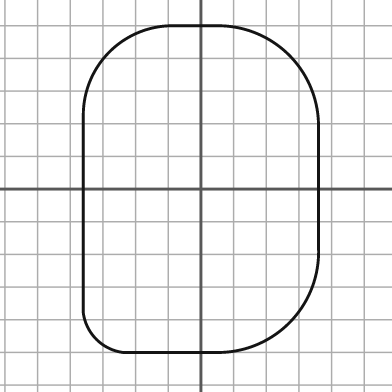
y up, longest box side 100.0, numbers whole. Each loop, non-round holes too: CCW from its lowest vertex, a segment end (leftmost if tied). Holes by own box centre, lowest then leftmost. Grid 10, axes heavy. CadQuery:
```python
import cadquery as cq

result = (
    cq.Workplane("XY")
    .moveTo(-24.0, -50.0)
    .lineTo(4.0, -50.0)
    .threePointArc((27.0, -41.0), (36.0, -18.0))
    .lineTo(36.0, 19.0)
    .threePointArc((27.0, 41.0), (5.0, 50.0))
    .lineTo(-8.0, 50.0)
    .threePointArc((-28.0, 42.0), (-36.0, 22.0))
    .lineTo(-36.0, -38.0)
    .threePointArc((-32.0, -46.0), (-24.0, -50.0))
    .close()
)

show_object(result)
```